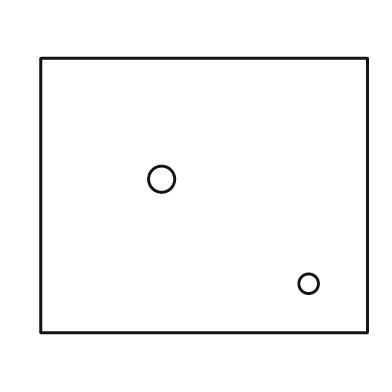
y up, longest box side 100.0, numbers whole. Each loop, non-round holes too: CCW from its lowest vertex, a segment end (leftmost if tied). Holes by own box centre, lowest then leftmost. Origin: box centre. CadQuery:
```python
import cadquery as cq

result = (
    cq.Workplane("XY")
    .moveTo(-50.0, -42.0)
    .lineTo(50.0, -42.0)
    .lineTo(50.0, 42.0)
    .lineTo(-50.0, 42.0)
    .close()
    .moveTo(32.0, -27.0)
    .circle(3.0)
    .moveTo(-13.0, 5.0)
    .circle(4.0)
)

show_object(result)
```